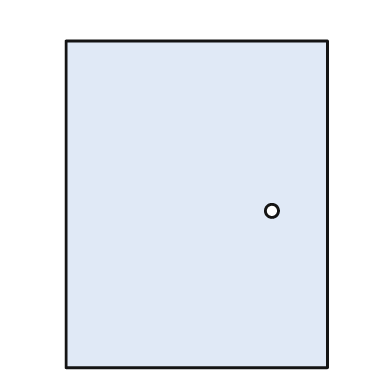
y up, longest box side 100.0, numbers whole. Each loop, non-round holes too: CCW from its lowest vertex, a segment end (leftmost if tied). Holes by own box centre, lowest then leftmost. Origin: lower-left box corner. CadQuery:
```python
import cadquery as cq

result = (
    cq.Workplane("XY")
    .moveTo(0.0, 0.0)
    .lineTo(80.0, 0.0)
    .lineTo(80.0, 100.0)
    .lineTo(0.0, 100.0)
    .close()
    .moveTo(63.0, 48.0)
    .circle(2.0)
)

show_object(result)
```